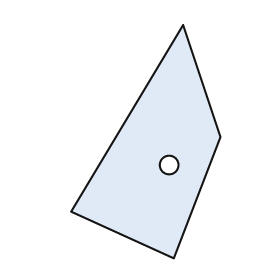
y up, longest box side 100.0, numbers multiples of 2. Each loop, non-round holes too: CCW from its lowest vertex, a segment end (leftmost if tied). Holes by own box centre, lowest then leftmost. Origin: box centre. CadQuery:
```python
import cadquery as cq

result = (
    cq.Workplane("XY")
    .moveTo(12.0, -50.0)
    .lineTo(32.0, 2.0)
    .lineTo(16.0, 50.0)
    .lineTo(-32.0, -30.0)
    .close()
    .moveTo(10.0, -10.0)
    .circle(4.0)
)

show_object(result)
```